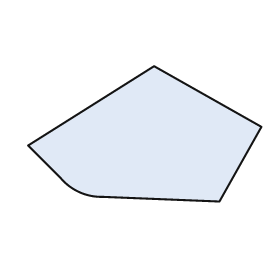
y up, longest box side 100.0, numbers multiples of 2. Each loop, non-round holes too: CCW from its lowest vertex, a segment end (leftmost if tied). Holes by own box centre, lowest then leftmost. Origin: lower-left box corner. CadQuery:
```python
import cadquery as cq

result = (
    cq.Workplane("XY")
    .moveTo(82.0, 0.0)
    .lineTo(100.0, 32.0)
    .lineTo(54.0, 58.0)
    .lineTo(0.0, 24.0)
    .lineTo(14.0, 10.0)
    .threePointArc((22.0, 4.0), (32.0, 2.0))
    .close()
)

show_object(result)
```